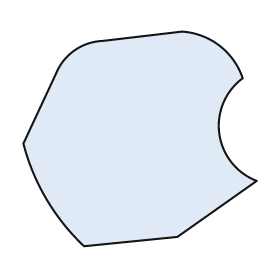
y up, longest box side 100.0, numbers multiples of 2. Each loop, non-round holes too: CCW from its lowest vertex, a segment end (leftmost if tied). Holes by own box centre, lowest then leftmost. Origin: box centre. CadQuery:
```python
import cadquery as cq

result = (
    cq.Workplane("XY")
    .moveTo(-24.0, -46.0)
    .lineTo(16.0, -42.0)
    .lineTo(50.0, -18.0)
    .threePointArc((34.0, 2.0), (44.0, 26.0))
    .threePointArc((34.0, 40.0), (18.0, 46.0))
    .lineTo(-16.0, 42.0)
    .threePointArc((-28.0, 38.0), (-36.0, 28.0))
    .lineTo(-50.0, -2.0)
    .threePointArc((-40.0, -26.0), (-24.0, -46.0))
    .close()
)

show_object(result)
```